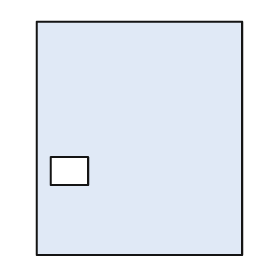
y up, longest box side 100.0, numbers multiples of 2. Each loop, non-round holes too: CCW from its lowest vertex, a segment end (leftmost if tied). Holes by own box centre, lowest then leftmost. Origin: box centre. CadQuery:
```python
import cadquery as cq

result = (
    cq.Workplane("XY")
    .moveTo(-44.0, -50.0)
    .lineTo(44.0, -50.0)
    .lineTo(44.0, 50.0)
    .lineTo(-44.0, 50.0)
    .close()
    .moveTo(-38.0, -20.0)
    .lineTo(-22.0, -20.0)
    .lineTo(-22.0, -8.0)
    .lineTo(-38.0, -8.0)
    .close()
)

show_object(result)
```